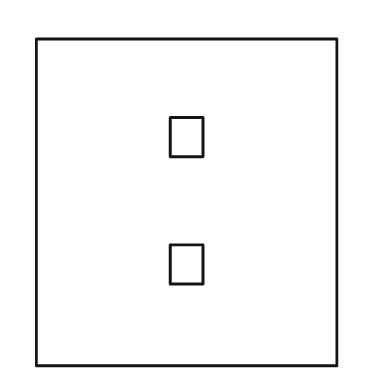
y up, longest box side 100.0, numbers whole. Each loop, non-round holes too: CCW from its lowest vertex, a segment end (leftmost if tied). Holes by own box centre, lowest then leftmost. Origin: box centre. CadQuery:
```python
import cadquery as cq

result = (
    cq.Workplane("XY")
    .moveTo(-46.0, -50.0)
    .lineTo(46.0, -50.0)
    .lineTo(46.0, 50.0)
    .lineTo(-46.0, 50.0)
    .close()
    .moveTo(-5.0, -25.0)
    .lineTo(5.0, -25.0)
    .lineTo(5.0, -13.0)
    .lineTo(-5.0, -13.0)
    .close()
    .moveTo(-5.0, 14.0)
    .lineTo(5.0, 14.0)
    .lineTo(5.0, 26.0)
    .lineTo(-5.0, 26.0)
    .close()
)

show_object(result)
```